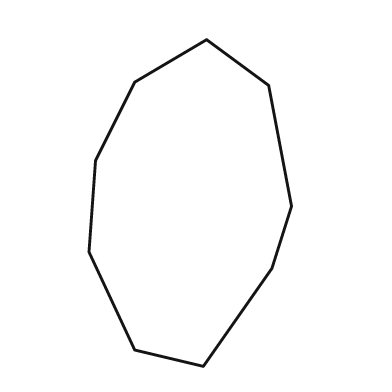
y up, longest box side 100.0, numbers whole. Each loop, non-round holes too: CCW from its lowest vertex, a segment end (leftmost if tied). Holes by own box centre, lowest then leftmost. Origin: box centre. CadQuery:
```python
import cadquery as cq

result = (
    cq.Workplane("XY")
    .moveTo(4.0, -50.0)
    .lineTo(25.0, -20.0)
    .lineTo(31.0, -1.0)
    .lineTo(24.0, 36.0)
    .lineTo(5.0, 50.0)
    .lineTo(-17.0, 37.0)
    .lineTo(-29.0, 13.0)
    .lineTo(-31.0, -15.0)
    .lineTo(-17.0, -45.0)
    .close()
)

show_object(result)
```